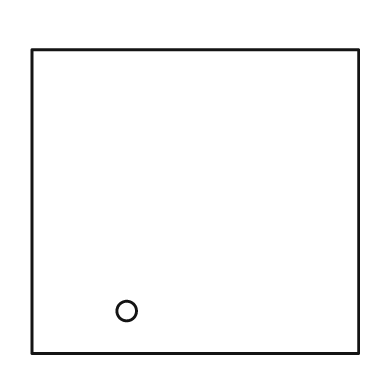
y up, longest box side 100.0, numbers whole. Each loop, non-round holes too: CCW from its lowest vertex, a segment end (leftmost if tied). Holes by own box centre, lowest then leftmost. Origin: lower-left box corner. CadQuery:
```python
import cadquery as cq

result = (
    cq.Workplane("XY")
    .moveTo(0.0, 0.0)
    .lineTo(100.0, 0.0)
    .lineTo(100.0, 93.0)
    .lineTo(0.0, 93.0)
    .close()
    .moveTo(29.0, 13.0)
    .circle(3.0)
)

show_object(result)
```